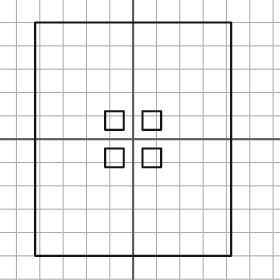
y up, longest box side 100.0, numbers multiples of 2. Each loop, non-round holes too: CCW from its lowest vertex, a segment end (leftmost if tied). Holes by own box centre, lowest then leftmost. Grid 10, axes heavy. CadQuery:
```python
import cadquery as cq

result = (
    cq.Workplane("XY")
    .moveTo(-42.0, -50.0)
    .lineTo(42.0, -50.0)
    .lineTo(42.0, 50.0)
    .lineTo(-42.0, 50.0)
    .close()
    .moveTo(-12.0, -12.0)
    .lineTo(-4.0, -12.0)
    .lineTo(-4.0, -4.0)
    .lineTo(-12.0, -4.0)
    .close()
    .moveTo(4.0, -12.0)
    .lineTo(12.0, -12.0)
    .lineTo(12.0, -4.0)
    .lineTo(4.0, -4.0)
    .close()
    .moveTo(-12.0, 4.0)
    .lineTo(-4.0, 4.0)
    .lineTo(-4.0, 12.0)
    .lineTo(-12.0, 12.0)
    .close()
    .moveTo(4.0, 4.0)
    .lineTo(12.0, 4.0)
    .lineTo(12.0, 12.0)
    .lineTo(4.0, 12.0)
    .close()
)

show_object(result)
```